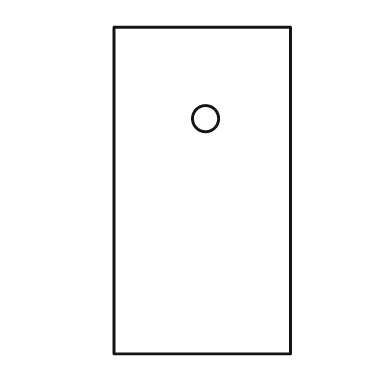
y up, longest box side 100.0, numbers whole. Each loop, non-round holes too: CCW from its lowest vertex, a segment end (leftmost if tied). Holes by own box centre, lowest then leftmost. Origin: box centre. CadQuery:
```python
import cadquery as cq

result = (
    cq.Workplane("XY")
    .moveTo(-27.0, -50.0)
    .lineTo(27.0, -50.0)
    .lineTo(27.0, 50.0)
    .lineTo(-27.0, 50.0)
    .close()
    .moveTo(1.0, 22.0)
    .circle(4.0)
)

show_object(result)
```